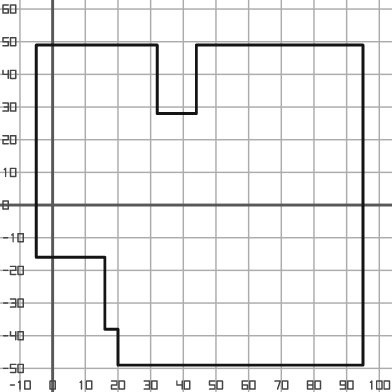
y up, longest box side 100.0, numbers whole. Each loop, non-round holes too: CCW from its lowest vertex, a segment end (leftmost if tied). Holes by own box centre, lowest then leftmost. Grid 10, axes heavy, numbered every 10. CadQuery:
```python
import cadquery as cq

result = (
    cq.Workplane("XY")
    .moveTo(20.0, -49.0)
    .lineTo(95.0, -49.0)
    .lineTo(95.0, 49.0)
    .lineTo(44.0, 49.0)
    .lineTo(44.0, 28.0)
    .lineTo(32.0, 28.0)
    .lineTo(32.0, 49.0)
    .lineTo(-5.0, 49.0)
    .lineTo(-5.0, -16.0)
    .lineTo(16.0, -16.0)
    .lineTo(16.0, -38.0)
    .lineTo(20.0, -38.0)
    .close()
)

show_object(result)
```